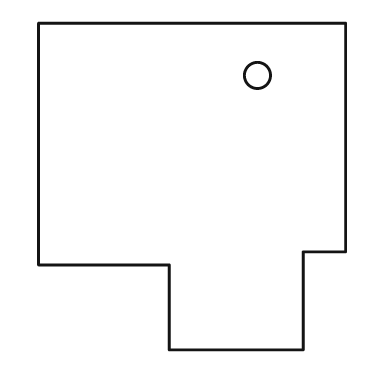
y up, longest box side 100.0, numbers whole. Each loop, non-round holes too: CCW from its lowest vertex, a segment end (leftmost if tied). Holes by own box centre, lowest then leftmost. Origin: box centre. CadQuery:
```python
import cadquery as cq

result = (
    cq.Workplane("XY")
    .moveTo(-7.0, -50.0)
    .lineTo(34.0, -50.0)
    .lineTo(34.0, -20.0)
    .lineTo(47.0, -20.0)
    .lineTo(47.0, 50.0)
    .lineTo(-47.0, 50.0)
    .lineTo(-47.0, -24.0)
    .lineTo(-7.0, -24.0)
    .close()
    .moveTo(20.0, 34.0)
    .circle(4.0)
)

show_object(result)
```